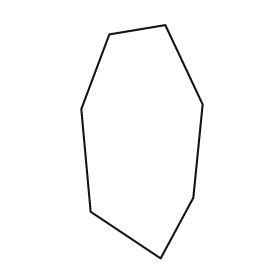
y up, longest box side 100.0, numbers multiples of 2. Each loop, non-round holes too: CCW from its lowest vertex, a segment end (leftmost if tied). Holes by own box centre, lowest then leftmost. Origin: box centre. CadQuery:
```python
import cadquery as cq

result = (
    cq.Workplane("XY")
    .moveTo(8.0, -50.0)
    .lineTo(22.0, -24.0)
    .lineTo(26.0, 16.0)
    .lineTo(10.0, 50.0)
    .lineTo(-14.0, 46.0)
    .lineTo(-26.0, 14.0)
    .lineTo(-22.0, -30.0)
    .close()
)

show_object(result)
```